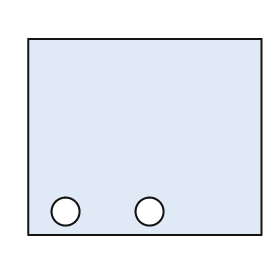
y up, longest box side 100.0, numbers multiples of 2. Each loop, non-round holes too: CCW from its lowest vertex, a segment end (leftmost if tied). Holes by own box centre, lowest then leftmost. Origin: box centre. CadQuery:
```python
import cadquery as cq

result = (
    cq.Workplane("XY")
    .moveTo(-50.0, -42.0)
    .lineTo(50.0, -42.0)
    .lineTo(50.0, 42.0)
    .lineTo(-50.0, 42.0)
    .close()
    .moveTo(-34.0, -32.0)
    .circle(6.0)
    .moveTo(2.0, -32.0)
    .circle(6.0)
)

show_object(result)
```